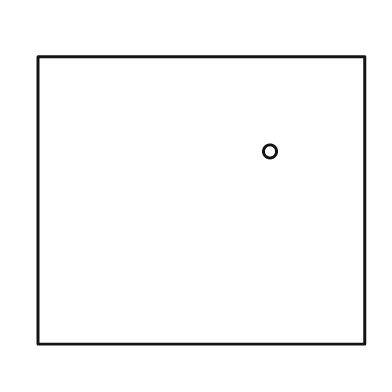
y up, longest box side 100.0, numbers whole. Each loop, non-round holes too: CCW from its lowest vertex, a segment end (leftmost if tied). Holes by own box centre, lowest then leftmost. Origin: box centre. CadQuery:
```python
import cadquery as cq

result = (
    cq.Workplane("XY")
    .moveTo(-50.0, -44.0)
    .lineTo(50.0, -44.0)
    .lineTo(50.0, 44.0)
    .lineTo(-50.0, 44.0)
    .close()
    .moveTo(21.0, 15.0)
    .circle(2.0)
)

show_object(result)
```